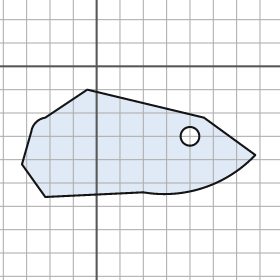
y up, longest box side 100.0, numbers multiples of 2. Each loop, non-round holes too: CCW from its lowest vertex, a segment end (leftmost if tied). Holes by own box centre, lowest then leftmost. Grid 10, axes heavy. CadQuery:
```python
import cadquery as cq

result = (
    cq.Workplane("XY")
    .moveTo(-22.0, -56.0)
    .lineTo(20.0, -54.0)
    .threePointArc((46.0, -52.0), (68.0, -38.0))
    .lineTo(46.0, -22.0)
    .lineTo(-4.0, -10.0)
    .lineTo(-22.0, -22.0)
    .threePointArc((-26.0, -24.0), (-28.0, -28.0))
    .lineTo(-32.0, -42.0)
    .close()
    .moveTo(40.0, -30.0)
    .circle(4.0)
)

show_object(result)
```